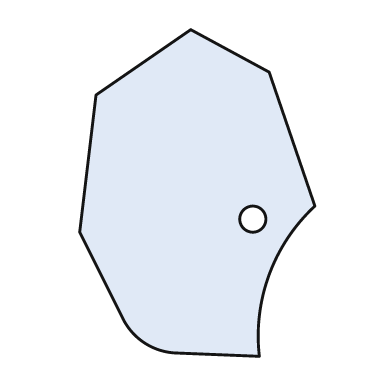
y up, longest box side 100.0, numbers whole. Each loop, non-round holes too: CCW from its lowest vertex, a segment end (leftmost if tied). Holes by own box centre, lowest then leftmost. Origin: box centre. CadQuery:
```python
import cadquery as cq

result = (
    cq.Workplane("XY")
    .moveTo(19.0, -50.0)
    .threePointArc((22.0, -25.0), (36.0, -4.0))
    .lineTo(22.0, 37.0)
    .lineTo(-2.0, 50.0)
    .lineTo(-31.0, 30.0)
    .lineTo(-36.0, -12.0)
    .lineTo(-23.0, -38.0)
    .threePointArc((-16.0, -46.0), (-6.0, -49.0))
    .close()
    .moveTo(17.0, -8.0)
    .circle(4.0)
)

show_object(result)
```